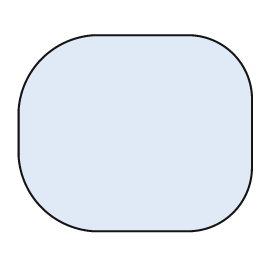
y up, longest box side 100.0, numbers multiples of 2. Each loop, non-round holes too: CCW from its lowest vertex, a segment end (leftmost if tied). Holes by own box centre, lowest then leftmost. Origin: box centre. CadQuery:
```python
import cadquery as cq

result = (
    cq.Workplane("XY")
    .moveTo(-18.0, -42.0)
    .lineTo(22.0, -42.0)
    .threePointArc((42.0, -34.0), (50.0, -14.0))
    .lineTo(50.0, 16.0)
    .threePointArc((42.0, 34.0), (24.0, 42.0))
    .lineTo(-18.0, 42.0)
    .threePointArc((-40.0, 32.0), (-50.0, 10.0))
    .lineTo(-50.0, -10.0)
    .threePointArc((-40.0, -32.0), (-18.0, -42.0))
    .close()
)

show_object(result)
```